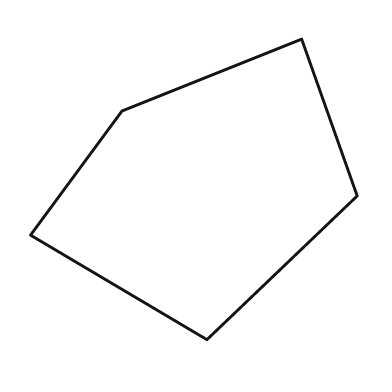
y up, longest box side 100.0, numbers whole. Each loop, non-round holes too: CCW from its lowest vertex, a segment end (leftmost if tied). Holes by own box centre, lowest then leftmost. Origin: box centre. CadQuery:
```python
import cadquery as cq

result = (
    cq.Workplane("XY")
    .moveTo(4.0, -46.0)
    .lineTo(50.0, -2.0)
    .lineTo(33.0, 46.0)
    .lineTo(-22.0, 24.0)
    .lineTo(-50.0, -14.0)
    .close()
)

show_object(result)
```